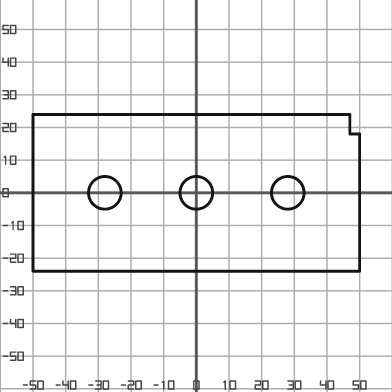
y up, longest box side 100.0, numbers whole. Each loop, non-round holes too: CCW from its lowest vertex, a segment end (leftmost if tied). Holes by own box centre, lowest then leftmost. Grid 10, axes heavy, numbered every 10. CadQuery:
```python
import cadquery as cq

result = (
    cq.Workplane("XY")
    .moveTo(-50.0, -24.0)
    .lineTo(50.0, -24.0)
    .lineTo(50.0, 18.0)
    .lineTo(47.0, 18.0)
    .lineTo(47.0, 24.0)
    .lineTo(-50.0, 24.0)
    .close()
    .moveTo(-28.0, 0.0)
    .circle(5.0)
    .moveTo(0.0, 0.0)
    .circle(5.0)
    .moveTo(28.0, 0.0)
    .circle(5.0)
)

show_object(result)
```